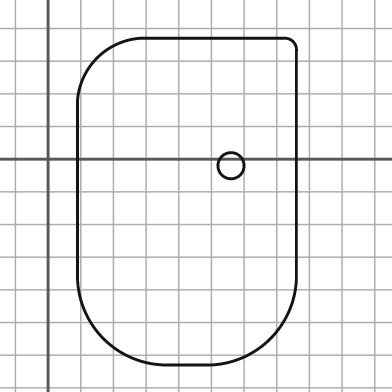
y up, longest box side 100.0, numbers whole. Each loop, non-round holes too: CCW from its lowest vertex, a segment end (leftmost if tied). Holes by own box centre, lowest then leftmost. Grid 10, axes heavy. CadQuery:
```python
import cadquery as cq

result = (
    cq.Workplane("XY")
    .moveTo(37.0, -63.0)
    .lineTo(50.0, -63.0)
    .threePointArc((68.0, -55.0), (76.0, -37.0))
    .lineTo(76.0, 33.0)
    .threePointArc((75.0, 36.0), (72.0, 37.0))
    .lineTo(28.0, 37.0)
    .threePointArc((15.0, 31.0), (9.0, 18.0))
    .lineTo(9.0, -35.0)
    .threePointArc((17.0, -55.0), (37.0, -63.0))
    .close()
    .moveTo(56.0, -2.0)
    .circle(4.0)
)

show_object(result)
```